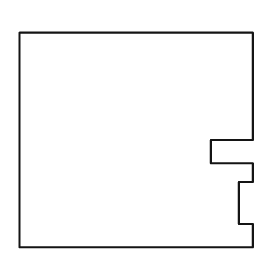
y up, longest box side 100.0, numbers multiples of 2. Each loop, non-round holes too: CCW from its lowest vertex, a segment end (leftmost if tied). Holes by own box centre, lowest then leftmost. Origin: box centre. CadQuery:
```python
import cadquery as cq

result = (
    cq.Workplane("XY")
    .moveTo(-50.0, -46.0)
    .lineTo(50.0, -46.0)
    .lineTo(50.0, -36.0)
    .lineTo(44.0, -36.0)
    .lineTo(44.0, -18.0)
    .lineTo(50.0, -18.0)
    .lineTo(50.0, -10.0)
    .lineTo(32.0, -10.0)
    .lineTo(32.0, 0.0)
    .lineTo(50.0, 0.0)
    .lineTo(50.0, 46.0)
    .lineTo(-50.0, 46.0)
    .close()
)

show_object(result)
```